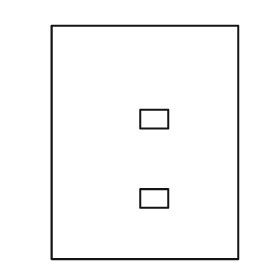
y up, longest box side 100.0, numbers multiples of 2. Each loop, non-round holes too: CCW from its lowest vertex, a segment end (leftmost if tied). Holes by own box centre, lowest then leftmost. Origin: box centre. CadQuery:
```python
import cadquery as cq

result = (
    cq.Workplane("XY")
    .moveTo(-40.0, -50.0)
    .lineTo(40.0, -50.0)
    .lineTo(40.0, 50.0)
    .lineTo(-40.0, 50.0)
    .close()
    .moveTo(-2.0, -28.0)
    .lineTo(10.0, -28.0)
    .lineTo(10.0, -20.0)
    .lineTo(-2.0, -20.0)
    .close()
    .moveTo(-2.0, 6.0)
    .lineTo(10.0, 6.0)
    .lineTo(10.0, 14.0)
    .lineTo(-2.0, 14.0)
    .close()
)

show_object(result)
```